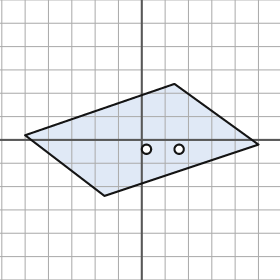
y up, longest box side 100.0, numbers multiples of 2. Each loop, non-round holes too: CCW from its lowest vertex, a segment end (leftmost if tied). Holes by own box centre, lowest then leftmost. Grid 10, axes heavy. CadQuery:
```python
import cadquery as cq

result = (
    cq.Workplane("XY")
    .moveTo(-16.0, -24.0)
    .lineTo(50.0, -2.0)
    .lineTo(14.0, 24.0)
    .lineTo(-50.0, 2.0)
    .close()
    .moveTo(2.0, -4.0)
    .circle(2.0)
    .moveTo(16.0, -4.0)
    .circle(2.0)
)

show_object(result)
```